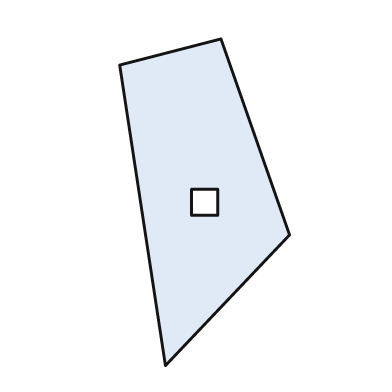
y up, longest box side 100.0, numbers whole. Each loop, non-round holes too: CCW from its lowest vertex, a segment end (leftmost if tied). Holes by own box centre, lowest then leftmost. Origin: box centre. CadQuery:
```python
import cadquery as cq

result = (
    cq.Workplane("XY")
    .moveTo(-12.0, -50.0)
    .lineTo(26.0, -10.0)
    .lineTo(5.0, 50.0)
    .lineTo(-26.0, 42.0)
    .close()
    .moveTo(-4.0, -4.0)
    .lineTo(4.0, -4.0)
    .lineTo(4.0, 4.0)
    .lineTo(-4.0, 4.0)
    .close()
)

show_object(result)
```